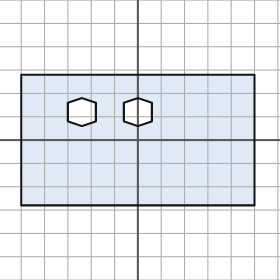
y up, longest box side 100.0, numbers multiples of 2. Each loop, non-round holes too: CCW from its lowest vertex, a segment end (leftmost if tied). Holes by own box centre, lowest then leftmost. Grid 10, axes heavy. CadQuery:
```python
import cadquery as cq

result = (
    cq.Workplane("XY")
    .moveTo(-50.0, -28.0)
    .lineTo(50.0, -28.0)
    .lineTo(50.0, 28.0)
    .lineTo(-50.0, 28.0)
    .close()
    .moveTo(-24.0, 6.0)
    .lineTo(-18.0, 8.0)
    .lineTo(-18.0, 16.0)
    .lineTo(-24.0, 18.0)
    .lineTo(-30.0, 16.0)
    .lineTo(-30.0, 8.0)
    .close()
    .moveTo(0.0, 6.0)
    .lineTo(6.0, 8.0)
    .lineTo(6.0, 16.0)
    .lineTo(0.0, 18.0)
    .lineTo(-6.0, 16.0)
    .lineTo(-6.0, 8.0)
    .close()
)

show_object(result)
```